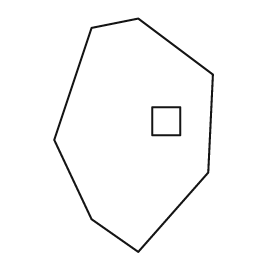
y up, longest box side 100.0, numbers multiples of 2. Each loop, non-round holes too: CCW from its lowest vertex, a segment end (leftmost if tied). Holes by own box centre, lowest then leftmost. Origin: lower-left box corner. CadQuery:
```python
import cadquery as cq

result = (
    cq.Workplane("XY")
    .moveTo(36.0, 0.0)
    .lineTo(66.0, 34.0)
    .lineTo(68.0, 76.0)
    .lineTo(36.0, 100.0)
    .lineTo(16.0, 96.0)
    .lineTo(0.0, 48.0)
    .lineTo(16.0, 14.0)
    .close()
    .moveTo(42.0, 50.0)
    .lineTo(54.0, 50.0)
    .lineTo(54.0, 62.0)
    .lineTo(42.0, 62.0)
    .close()
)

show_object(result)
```